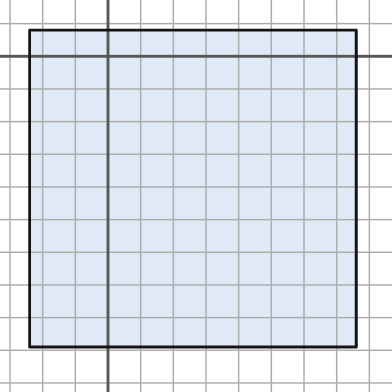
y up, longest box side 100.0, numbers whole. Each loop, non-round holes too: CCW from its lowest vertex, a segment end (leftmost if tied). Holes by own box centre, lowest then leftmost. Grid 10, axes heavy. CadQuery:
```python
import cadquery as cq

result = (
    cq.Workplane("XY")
    .moveTo(-24.0, -89.0)
    .lineTo(76.0, -89.0)
    .lineTo(76.0, 8.0)
    .lineTo(-24.0, 8.0)
    .close()
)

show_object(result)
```